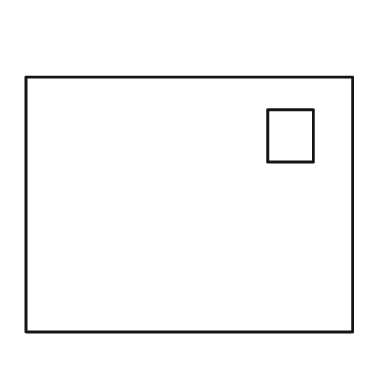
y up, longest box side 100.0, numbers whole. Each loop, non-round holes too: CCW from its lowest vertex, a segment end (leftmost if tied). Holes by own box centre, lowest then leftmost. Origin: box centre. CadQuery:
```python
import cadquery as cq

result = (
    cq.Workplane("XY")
    .moveTo(-50.0, -39.0)
    .lineTo(50.0, -39.0)
    .lineTo(50.0, 39.0)
    .lineTo(-50.0, 39.0)
    .close()
    .moveTo(24.0, 13.0)
    .lineTo(38.0, 13.0)
    .lineTo(38.0, 29.0)
    .lineTo(24.0, 29.0)
    .close()
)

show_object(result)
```